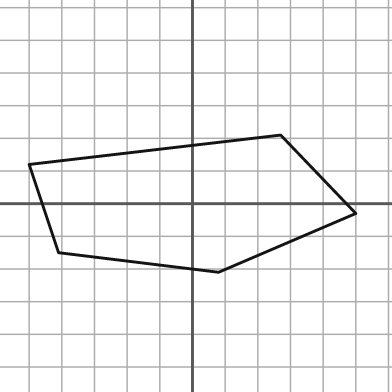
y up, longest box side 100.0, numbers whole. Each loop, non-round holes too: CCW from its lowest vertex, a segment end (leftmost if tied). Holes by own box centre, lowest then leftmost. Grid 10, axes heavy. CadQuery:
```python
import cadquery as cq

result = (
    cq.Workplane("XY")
    .moveTo(8.0, -21.0)
    .lineTo(50.0, -3.0)
    .lineTo(27.0, 21.0)
    .lineTo(-50.0, 12.0)
    .lineTo(-41.0, -15.0)
    .close()
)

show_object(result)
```